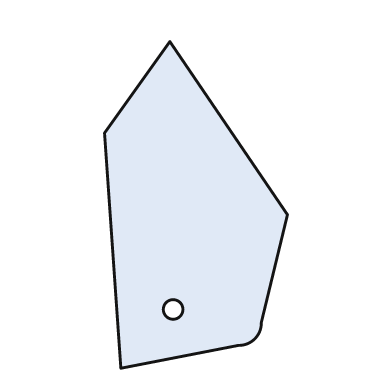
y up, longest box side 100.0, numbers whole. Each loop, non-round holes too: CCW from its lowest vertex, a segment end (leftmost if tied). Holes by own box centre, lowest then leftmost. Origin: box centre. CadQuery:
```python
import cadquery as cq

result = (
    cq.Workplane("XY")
    .moveTo(-23.0, -50.0)
    .lineTo(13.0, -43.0)
    .threePointArc((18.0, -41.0), (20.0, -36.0))
    .lineTo(28.0, -3.0)
    .lineTo(-8.0, 50.0)
    .lineTo(-28.0, 22.0)
    .close()
    .moveTo(-7.0, -32.0)
    .circle(3.0)
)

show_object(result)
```